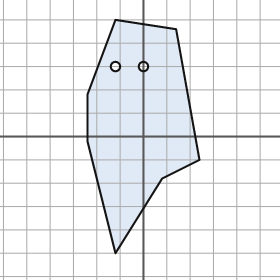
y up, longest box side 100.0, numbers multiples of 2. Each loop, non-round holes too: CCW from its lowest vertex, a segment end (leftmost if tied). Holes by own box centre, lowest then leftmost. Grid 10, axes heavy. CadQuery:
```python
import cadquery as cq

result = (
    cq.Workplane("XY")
    .moveTo(-12.0, -50.0)
    .lineTo(8.0, -18.0)
    .lineTo(24.0, -10.0)
    .lineTo(14.0, 46.0)
    .lineTo(-12.0, 50.0)
    .lineTo(-24.0, 18.0)
    .lineTo(-24.0, -2.0)
    .close()
    .moveTo(-12.0, 30.0)
    .circle(2.0)
    .moveTo(0.0, 30.0)
    .circle(2.0)
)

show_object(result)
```